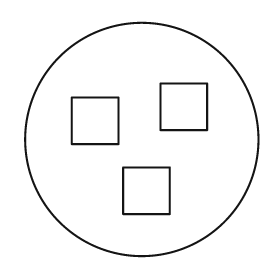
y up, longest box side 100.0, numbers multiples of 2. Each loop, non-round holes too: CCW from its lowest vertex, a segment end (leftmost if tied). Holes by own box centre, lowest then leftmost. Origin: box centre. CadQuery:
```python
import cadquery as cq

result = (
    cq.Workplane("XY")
    .moveTo(0.0, 0.0)
    .circle(50.0)
    .moveTo(-8.0, -32.0)
    .lineTo(12.0, -32.0)
    .lineTo(12.0, -12.0)
    .lineTo(-8.0, -12.0)
    .close()
    .moveTo(-30.0, -2.0)
    .lineTo(-10.0, -2.0)
    .lineTo(-10.0, 18.0)
    .lineTo(-30.0, 18.0)
    .close()
    .moveTo(8.0, 4.0)
    .lineTo(28.0, 4.0)
    .lineTo(28.0, 24.0)
    .lineTo(8.0, 24.0)
    .close()
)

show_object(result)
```